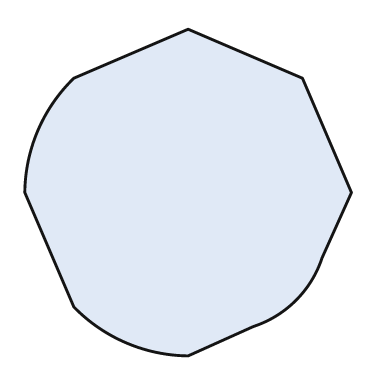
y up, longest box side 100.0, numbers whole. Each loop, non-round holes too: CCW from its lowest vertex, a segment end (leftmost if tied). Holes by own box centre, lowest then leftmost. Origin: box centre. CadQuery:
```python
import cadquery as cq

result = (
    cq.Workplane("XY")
    .moveTo(0.0, -50.0)
    .lineTo(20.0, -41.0)
    .threePointArc((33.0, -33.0), (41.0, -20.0))
    .lineTo(50.0, 0.0)
    .lineTo(35.0, 35.0)
    .lineTo(0.0, 50.0)
    .lineTo(-35.0, 35.0)
    .threePointArc((-46.0, 19.0), (-50.0, 0.0))
    .lineTo(-35.0, -35.0)
    .threePointArc((-19.0, -46.0), (0.0, -50.0))
    .close()
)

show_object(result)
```